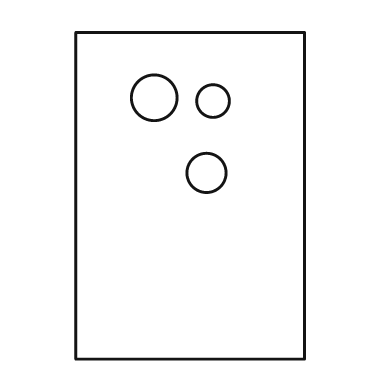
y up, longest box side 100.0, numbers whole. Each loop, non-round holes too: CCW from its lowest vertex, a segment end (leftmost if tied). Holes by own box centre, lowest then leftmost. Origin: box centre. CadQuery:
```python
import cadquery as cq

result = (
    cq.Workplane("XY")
    .moveTo(-35.0, -50.0)
    .lineTo(35.0, -50.0)
    .lineTo(35.0, 50.0)
    .lineTo(-35.0, 50.0)
    .close()
    .moveTo(5.0, 7.0)
    .circle(6.0)
    .moveTo(7.0, 29.0)
    .circle(5.0)
    .moveTo(-11.0, 30.0)
    .circle(7.0)
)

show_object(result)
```